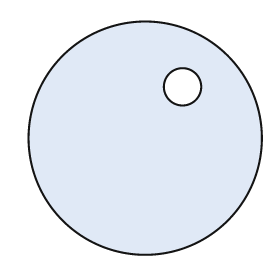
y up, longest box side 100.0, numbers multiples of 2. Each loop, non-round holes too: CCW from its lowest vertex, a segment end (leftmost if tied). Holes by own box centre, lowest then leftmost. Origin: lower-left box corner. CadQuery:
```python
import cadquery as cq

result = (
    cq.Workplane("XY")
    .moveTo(50.0, 50.0)
    .circle(50.0)
    .moveTo(66.0, 72.0)
    .circle(8.0)
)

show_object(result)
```